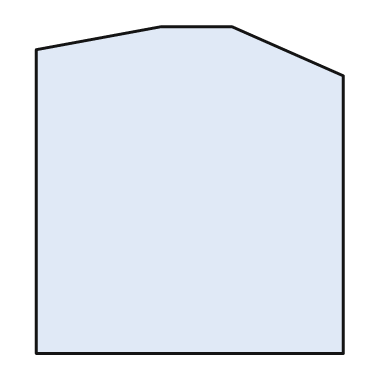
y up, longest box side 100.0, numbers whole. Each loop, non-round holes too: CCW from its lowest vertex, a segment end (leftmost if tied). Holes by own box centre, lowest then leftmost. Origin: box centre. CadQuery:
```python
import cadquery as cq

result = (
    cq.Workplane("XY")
    .moveTo(-47.0, -50.0)
    .lineTo(47.0, -50.0)
    .lineTo(47.0, 35.0)
    .lineTo(13.0, 50.0)
    .lineTo(-9.0, 50.0)
    .lineTo(-47.0, 43.0)
    .close()
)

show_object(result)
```